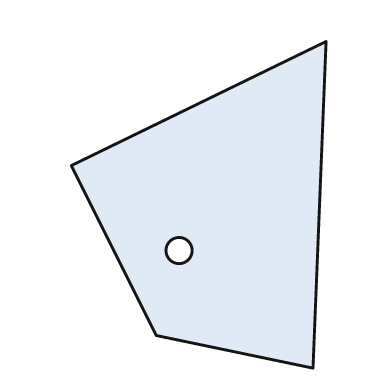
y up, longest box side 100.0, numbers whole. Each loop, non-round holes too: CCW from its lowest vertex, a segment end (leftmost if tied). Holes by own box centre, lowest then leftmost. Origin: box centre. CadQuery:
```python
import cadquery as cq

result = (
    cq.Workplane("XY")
    .moveTo(35.0, -50.0)
    .lineTo(39.0, 50.0)
    .lineTo(-39.0, 12.0)
    .lineTo(-13.0, -40.0)
    .close()
    .moveTo(-6.0, -14.0)
    .circle(4.0)
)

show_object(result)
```